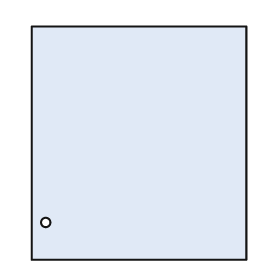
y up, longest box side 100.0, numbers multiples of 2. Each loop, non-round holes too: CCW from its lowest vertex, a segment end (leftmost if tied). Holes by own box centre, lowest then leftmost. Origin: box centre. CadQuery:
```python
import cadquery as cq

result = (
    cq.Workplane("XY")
    .moveTo(-46.0, -50.0)
    .lineTo(46.0, -50.0)
    .lineTo(46.0, 50.0)
    .lineTo(-46.0, 50.0)
    .close()
    .moveTo(-40.0, -34.0)
    .circle(2.0)
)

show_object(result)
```